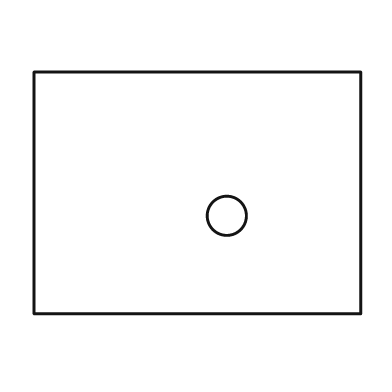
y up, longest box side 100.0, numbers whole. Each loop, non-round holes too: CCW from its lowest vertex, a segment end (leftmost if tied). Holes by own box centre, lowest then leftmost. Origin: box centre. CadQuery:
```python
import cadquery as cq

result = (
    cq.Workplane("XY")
    .moveTo(-50.0, -37.0)
    .lineTo(50.0, -37.0)
    .lineTo(50.0, 37.0)
    .lineTo(-50.0, 37.0)
    .close()
    .moveTo(9.0, -7.0)
    .circle(6.0)
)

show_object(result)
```